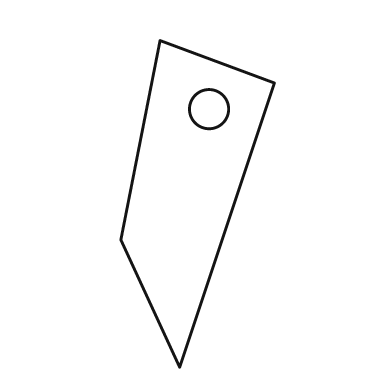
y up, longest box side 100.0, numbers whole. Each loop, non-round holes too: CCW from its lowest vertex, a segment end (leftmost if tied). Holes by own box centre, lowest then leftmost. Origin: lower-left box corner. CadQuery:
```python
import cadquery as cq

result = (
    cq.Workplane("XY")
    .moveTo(18.0, 0.0)
    .lineTo(47.0, 87.0)
    .lineTo(12.0, 100.0)
    .lineTo(0.0, 39.0)
    .close()
    .moveTo(27.0, 79.0)
    .circle(6.0)
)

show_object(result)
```